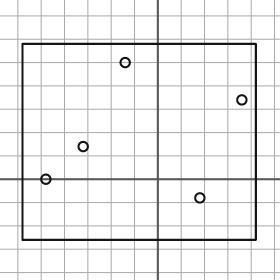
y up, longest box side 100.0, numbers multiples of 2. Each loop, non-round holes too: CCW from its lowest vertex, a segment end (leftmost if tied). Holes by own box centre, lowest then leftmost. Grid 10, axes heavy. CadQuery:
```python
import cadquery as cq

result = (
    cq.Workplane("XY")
    .moveTo(-58.0, -26.0)
    .lineTo(42.0, -26.0)
    .lineTo(42.0, 58.0)
    .lineTo(-58.0, 58.0)
    .close()
    .moveTo(18.0, -8.0)
    .circle(2.0)
    .moveTo(-48.0, 0.0)
    .circle(2.0)
    .moveTo(-32.0, 14.0)
    .circle(2.0)
    .moveTo(36.0, 34.0)
    .circle(2.0)
    .moveTo(-14.0, 50.0)
    .circle(2.0)
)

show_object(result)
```